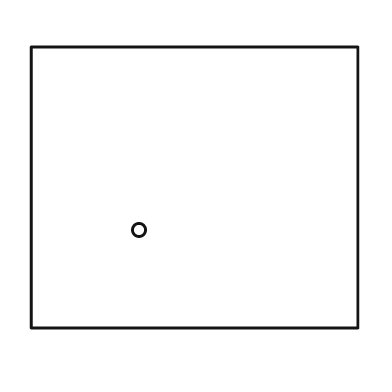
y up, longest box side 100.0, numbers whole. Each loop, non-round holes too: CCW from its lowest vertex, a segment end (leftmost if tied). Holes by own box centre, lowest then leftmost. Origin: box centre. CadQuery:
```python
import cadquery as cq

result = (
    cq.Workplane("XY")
    .moveTo(-50.0, -43.0)
    .lineTo(50.0, -43.0)
    .lineTo(50.0, 43.0)
    .lineTo(-50.0, 43.0)
    .close()
    .moveTo(-17.0, -13.0)
    .circle(2.0)
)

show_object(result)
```